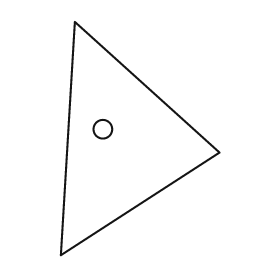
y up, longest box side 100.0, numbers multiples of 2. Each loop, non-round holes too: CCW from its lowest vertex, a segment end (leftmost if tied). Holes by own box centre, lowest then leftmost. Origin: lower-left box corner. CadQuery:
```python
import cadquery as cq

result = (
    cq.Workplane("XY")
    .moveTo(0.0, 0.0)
    .lineTo(68.0, 44.0)
    .lineTo(6.0, 100.0)
    .close()
    .moveTo(18.0, 54.0)
    .circle(4.0)
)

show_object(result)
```